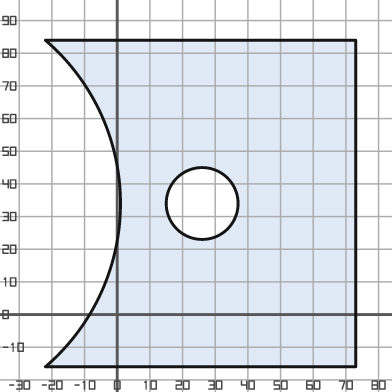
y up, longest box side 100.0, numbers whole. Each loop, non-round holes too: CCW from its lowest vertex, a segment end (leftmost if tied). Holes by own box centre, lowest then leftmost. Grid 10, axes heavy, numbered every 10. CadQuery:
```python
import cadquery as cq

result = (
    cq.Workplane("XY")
    .moveTo(-22.0, -16.0)
    .lineTo(73.0, -16.0)
    .lineTo(73.0, 84.0)
    .lineTo(-22.0, 84.0)
    .threePointArc((1.0, 34.0), (-22.0, -16.0))
    .close()
    .moveTo(26.0, 34.0)
    .circle(11.0)
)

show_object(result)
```